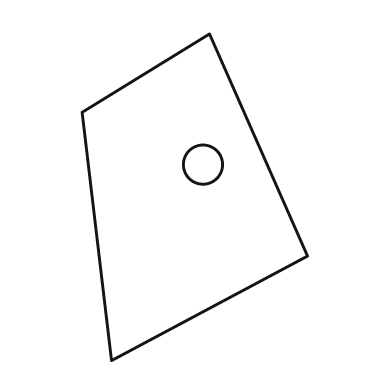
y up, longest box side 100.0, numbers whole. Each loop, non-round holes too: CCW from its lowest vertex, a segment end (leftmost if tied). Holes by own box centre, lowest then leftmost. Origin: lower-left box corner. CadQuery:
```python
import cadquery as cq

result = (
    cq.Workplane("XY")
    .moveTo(9.0, 0.0)
    .lineTo(69.0, 32.0)
    .lineTo(39.0, 100.0)
    .lineTo(0.0, 76.0)
    .close()
    .moveTo(37.0, 60.0)
    .circle(6.0)
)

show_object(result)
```